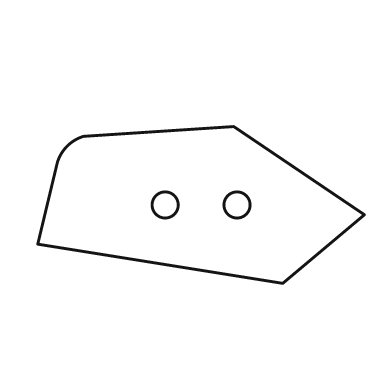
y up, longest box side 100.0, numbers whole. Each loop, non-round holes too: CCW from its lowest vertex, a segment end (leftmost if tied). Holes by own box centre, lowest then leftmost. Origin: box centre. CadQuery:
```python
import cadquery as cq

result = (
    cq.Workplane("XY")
    .moveTo(25.0, -24.0)
    .lineTo(50.0, -3.0)
    .lineTo(10.0, 24.0)
    .lineTo(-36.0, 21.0)
    .threePointArc((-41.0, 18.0), (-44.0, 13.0))
    .lineTo(-50.0, -12.0)
    .close()
    .moveTo(-11.0, 0.0)
    .circle(4.0)
    .moveTo(11.0, 0.0)
    .circle(4.0)
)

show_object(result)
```